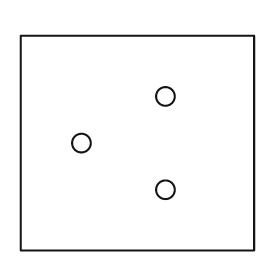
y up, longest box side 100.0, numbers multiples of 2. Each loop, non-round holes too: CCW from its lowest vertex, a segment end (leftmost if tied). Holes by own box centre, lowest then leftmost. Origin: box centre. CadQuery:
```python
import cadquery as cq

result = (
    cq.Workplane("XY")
    .moveTo(-50.0, -46.0)
    .lineTo(50.0, -46.0)
    .lineTo(50.0, 46.0)
    .lineTo(-50.0, 46.0)
    .close()
    .moveTo(12.0, -20.0)
    .circle(4.0)
    .moveTo(-24.0, 0.0)
    .circle(4.0)
    .moveTo(12.0, 20.0)
    .circle(4.0)
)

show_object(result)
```